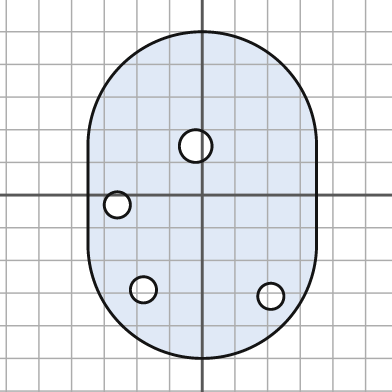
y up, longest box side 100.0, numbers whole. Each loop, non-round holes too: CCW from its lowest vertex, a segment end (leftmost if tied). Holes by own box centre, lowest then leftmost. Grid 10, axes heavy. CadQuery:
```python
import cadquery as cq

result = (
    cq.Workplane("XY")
    .moveTo(-35.0, -15.0)
    .threePointArc((0.0, -50.0), (35.0, -15.0))
    .lineTo(35.0, 15.0)
    .threePointArc((0.0, 50.0), (-35.0, 15.0))
    .close()
    .moveTo(21.0, -31.0)
    .circle(4.0)
    .moveTo(-18.0, -29.0)
    .circle(4.0)
    .moveTo(-26.0, -3.0)
    .circle(4.0)
    .moveTo(-2.0, 15.0)
    .circle(5.0)
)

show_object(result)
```